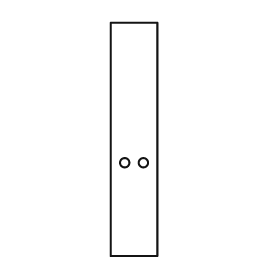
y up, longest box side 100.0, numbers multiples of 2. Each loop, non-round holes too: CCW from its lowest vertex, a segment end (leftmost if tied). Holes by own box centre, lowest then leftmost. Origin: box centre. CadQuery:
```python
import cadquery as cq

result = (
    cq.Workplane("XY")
    .moveTo(-10.0, -50.0)
    .lineTo(10.0, -50.0)
    .lineTo(10.0, 50.0)
    .lineTo(-10.0, 50.0)
    .close()
    .moveTo(-4.0, -10.0)
    .circle(2.0)
    .moveTo(4.0, -10.0)
    .circle(2.0)
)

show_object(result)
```